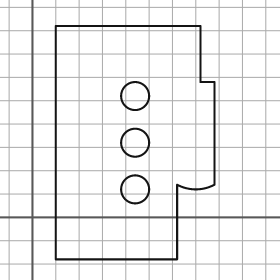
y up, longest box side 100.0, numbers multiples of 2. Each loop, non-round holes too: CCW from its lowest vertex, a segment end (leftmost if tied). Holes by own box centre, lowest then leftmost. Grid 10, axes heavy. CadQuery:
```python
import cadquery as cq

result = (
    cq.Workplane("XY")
    .moveTo(10.0, -18.0)
    .lineTo(62.0, -18.0)
    .lineTo(62.0, 14.0)
    .threePointArc((70.0, 12.0), (78.0, 14.0))
    .lineTo(78.0, 58.0)
    .lineTo(72.0, 58.0)
    .lineTo(72.0, 82.0)
    .lineTo(10.0, 82.0)
    .close()
    .moveTo(44.0, 12.0)
    .circle(6.0)
    .moveTo(44.0, 32.0)
    .circle(6.0)
    .moveTo(44.0, 52.0)
    .circle(6.0)
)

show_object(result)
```